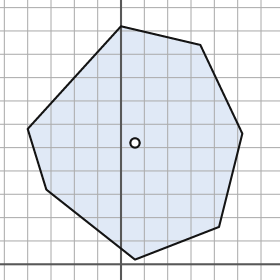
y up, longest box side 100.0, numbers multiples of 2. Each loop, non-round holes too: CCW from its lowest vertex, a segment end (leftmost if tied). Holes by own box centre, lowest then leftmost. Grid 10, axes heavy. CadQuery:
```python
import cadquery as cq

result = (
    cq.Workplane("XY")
    .moveTo(6.0, 2.0)
    .lineTo(42.0, 16.0)
    .lineTo(52.0, 56.0)
    .lineTo(34.0, 94.0)
    .lineTo(0.0, 102.0)
    .lineTo(-40.0, 58.0)
    .lineTo(-32.0, 32.0)
    .close()
    .moveTo(6.0, 52.0)
    .circle(2.0)
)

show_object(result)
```